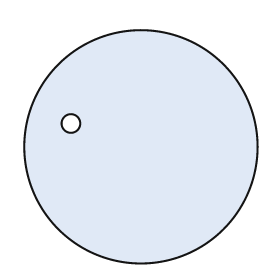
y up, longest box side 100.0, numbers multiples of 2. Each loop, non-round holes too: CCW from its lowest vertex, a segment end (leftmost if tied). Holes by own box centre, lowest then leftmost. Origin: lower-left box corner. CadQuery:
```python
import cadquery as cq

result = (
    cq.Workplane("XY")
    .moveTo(50.0, 50.0)
    .circle(50.0)
    .moveTo(20.0, 60.0)
    .circle(4.0)
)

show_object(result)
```